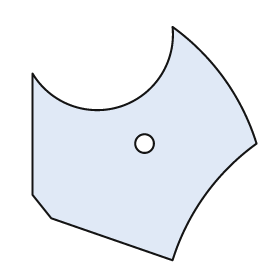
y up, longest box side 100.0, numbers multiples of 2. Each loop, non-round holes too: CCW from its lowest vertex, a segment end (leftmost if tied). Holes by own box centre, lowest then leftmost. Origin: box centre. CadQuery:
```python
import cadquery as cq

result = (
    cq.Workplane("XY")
    .moveTo(12.0, -50.0)
    .threePointArc((26.0, -22.0), (48.0, 0.0))
    .threePointArc((34.0, 28.0), (12.0, 50.0))
    .threePointArc((-10.0, 16.0), (-48.0, 30.0))
    .lineTo(-48.0, -22.0)
    .lineTo(-40.0, -32.0)
    .close()
    .moveTo(0.0, 0.0)
    .circle(4.0)
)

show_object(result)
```